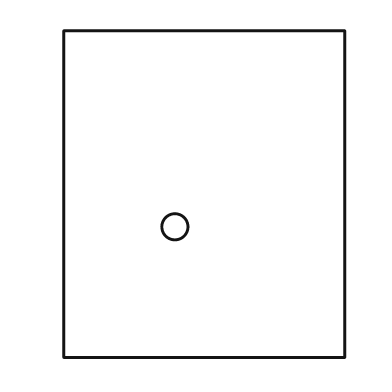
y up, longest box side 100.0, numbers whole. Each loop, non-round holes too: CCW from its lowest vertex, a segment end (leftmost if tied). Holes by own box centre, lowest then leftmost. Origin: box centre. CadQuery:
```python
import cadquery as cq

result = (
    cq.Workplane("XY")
    .moveTo(-43.0, -50.0)
    .lineTo(43.0, -50.0)
    .lineTo(43.0, 50.0)
    .lineTo(-43.0, 50.0)
    .close()
    .moveTo(-9.0, -10.0)
    .circle(4.0)
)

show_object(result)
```